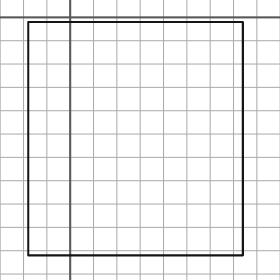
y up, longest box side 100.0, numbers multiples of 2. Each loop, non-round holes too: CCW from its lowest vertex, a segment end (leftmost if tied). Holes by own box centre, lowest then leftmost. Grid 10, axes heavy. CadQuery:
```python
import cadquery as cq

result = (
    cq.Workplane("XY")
    .moveTo(-18.0, -102.0)
    .lineTo(74.0, -102.0)
    .lineTo(74.0, -2.0)
    .lineTo(-18.0, -2.0)
    .close()
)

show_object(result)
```